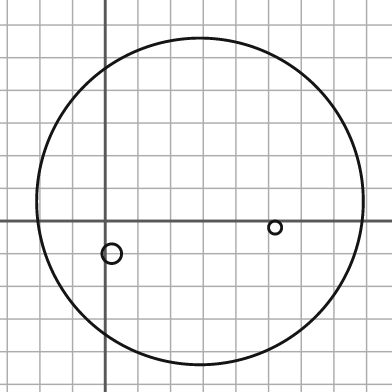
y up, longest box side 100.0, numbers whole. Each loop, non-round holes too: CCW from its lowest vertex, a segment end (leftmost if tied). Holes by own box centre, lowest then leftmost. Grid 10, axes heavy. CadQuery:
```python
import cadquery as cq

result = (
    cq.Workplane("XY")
    .moveTo(29.0, 6.0)
    .circle(50.0)
    .moveTo(2.0, -10.0)
    .circle(3.0)
    .moveTo(52.0, -2.0)
    .circle(2.0)
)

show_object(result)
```